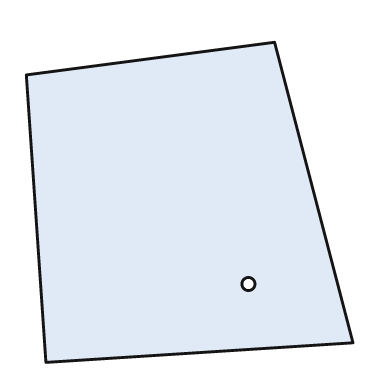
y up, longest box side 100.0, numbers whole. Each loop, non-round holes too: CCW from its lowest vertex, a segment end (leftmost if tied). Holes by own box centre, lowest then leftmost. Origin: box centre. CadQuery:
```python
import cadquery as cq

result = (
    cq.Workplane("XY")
    .moveTo(-44.0, -49.0)
    .lineTo(50.0, -43.0)
    .lineTo(26.0, 49.0)
    .lineTo(-50.0, 39.0)
    .close()
    .moveTo(18.0, -25.0)
    .circle(2.0)
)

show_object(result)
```